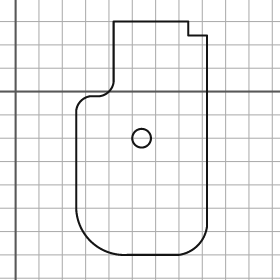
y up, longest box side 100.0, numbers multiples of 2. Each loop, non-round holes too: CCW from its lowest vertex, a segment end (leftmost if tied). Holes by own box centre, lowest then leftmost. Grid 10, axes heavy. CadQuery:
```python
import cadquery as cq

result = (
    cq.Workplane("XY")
    .moveTo(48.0, -70.0)
    .lineTo(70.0, -70.0)
    .threePointArc((78.0, -66.0), (82.0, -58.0))
    .lineTo(82.0, 24.0)
    .lineTo(74.0, 24.0)
    .lineTo(74.0, 30.0)
    .lineTo(42.0, 30.0)
    .lineTo(42.0, 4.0)
    .threePointArc((40.0, 0.0), (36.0, -2.0))
    .lineTo(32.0, -2.0)
    .threePointArc((28.0, -4.0), (26.0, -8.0))
    .lineTo(26.0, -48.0)
    .threePointArc((32.0, -64.0), (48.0, -70.0))
    .close()
    .moveTo(54.0, -20.0)
    .circle(4.0)
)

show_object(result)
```